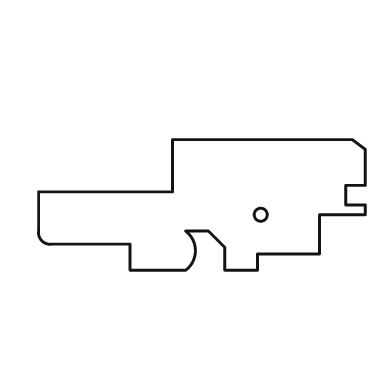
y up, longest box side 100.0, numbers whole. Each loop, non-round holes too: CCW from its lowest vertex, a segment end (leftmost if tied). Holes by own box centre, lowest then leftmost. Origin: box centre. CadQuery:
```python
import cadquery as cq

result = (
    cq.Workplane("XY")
    .moveTo(-22.0, -20.0)
    .lineTo(-5.0, -20.0)
    .threePointArc((-2.0, -14.0), (-5.0, -8.0))
    .lineTo(2.0, -8.0)
    .lineTo(7.0, -13.0)
    .lineTo(7.0, -20.0)
    .lineTo(17.0, -20.0)
    .lineTo(17.0, -15.0)
    .lineTo(36.0, -15.0)
    .lineTo(36.0, -3.0)
    .lineTo(50.0, -3.0)
    .lineTo(50.0, 0.0)
    .lineTo(44.0, 0.0)
    .lineTo(44.0, 6.0)
    .lineTo(50.0, 6.0)
    .lineTo(50.0, 17.0)
    .lineTo(46.0, 20.0)
    .lineTo(-9.0, 20.0)
    .lineTo(-9.0, 4.0)
    .lineTo(-50.0, 4.0)
    .lineTo(-50.0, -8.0)
    .threePointArc((-49.0, -11.0), (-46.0, -12.0))
    .lineTo(-22.0, -12.0)
    .close()
    .moveTo(18.0, -3.0)
    .circle(2.0)
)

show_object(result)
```